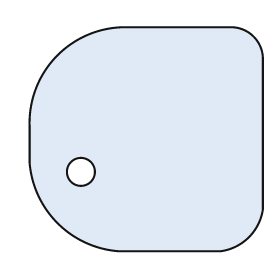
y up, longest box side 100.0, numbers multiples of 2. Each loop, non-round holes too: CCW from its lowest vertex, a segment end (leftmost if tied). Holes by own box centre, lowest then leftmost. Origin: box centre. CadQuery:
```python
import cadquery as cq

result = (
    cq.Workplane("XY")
    .moveTo(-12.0, -48.0)
    .lineTo(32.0, -48.0)
    .threePointArc((44.0, -42.0), (50.0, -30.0))
    .lineTo(50.0, 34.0)
    .threePointArc((46.0, 44.0), (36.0, 48.0))
    .lineTo(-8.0, 48.0)
    .threePointArc((-38.0, 36.0), (-50.0, 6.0))
    .lineTo(-50.0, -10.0)
    .threePointArc((-38.0, -36.0), (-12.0, -48.0))
    .close()
    .moveTo(-28.0, -14.0)
    .circle(6.0)
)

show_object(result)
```